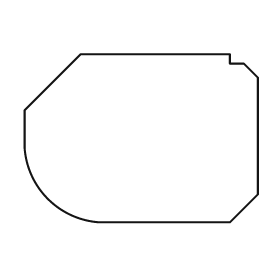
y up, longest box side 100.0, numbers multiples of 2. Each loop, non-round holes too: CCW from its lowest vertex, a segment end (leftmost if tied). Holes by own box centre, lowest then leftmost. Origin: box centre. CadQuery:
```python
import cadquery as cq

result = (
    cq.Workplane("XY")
    .moveTo(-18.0, -36.0)
    .lineTo(38.0, -36.0)
    .lineTo(50.0, -24.0)
    .lineTo(50.0, 26.0)
    .lineTo(44.0, 32.0)
    .lineTo(38.0, 32.0)
    .lineTo(38.0, 36.0)
    .lineTo(-26.0, 36.0)
    .lineTo(-50.0, 12.0)
    .lineTo(-50.0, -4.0)
    .threePointArc((-40.0, -26.0), (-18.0, -36.0))
    .close()
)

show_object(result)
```